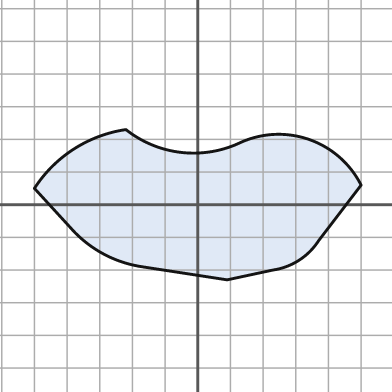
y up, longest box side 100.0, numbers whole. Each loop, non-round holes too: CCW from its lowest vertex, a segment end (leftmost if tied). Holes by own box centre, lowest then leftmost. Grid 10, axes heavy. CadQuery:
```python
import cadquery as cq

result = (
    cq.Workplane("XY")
    .moveTo(9.0, -23.0)
    .lineTo(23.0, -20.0)
    .threePointArc((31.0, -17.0), (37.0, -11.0))
    .lineTo(50.0, 6.0)
    .threePointArc((34.0, 20.0), (13.0, 19.0))
    .threePointArc((-5.0, 16.0), (-22.0, 23.0))
    .threePointArc((-38.0, 17.0), (-50.0, 5.0))
    .lineTo(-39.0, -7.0)
    .threePointArc((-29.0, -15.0), (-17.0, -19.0))
    .close()
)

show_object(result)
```